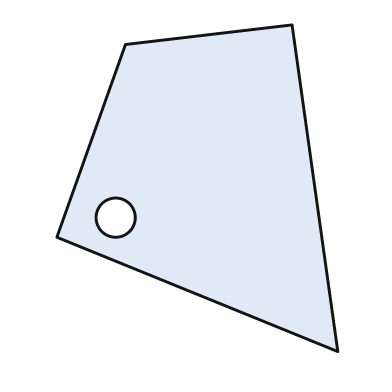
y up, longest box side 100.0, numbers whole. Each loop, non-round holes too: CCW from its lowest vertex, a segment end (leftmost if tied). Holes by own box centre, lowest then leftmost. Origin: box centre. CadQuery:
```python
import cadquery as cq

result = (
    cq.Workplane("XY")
    .moveTo(43.0, -50.0)
    .lineTo(29.0, 50.0)
    .lineTo(-22.0, 44.0)
    .lineTo(-43.0, -15.0)
    .close()
    .moveTo(-25.0, -9.0)
    .circle(6.0)
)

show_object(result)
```